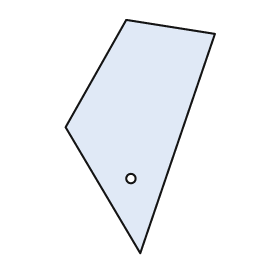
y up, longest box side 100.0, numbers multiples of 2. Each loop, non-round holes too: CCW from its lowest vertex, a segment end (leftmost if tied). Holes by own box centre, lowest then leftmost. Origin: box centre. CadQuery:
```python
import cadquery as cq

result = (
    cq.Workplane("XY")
    .moveTo(0.0, -50.0)
    .lineTo(32.0, 44.0)
    .lineTo(-6.0, 50.0)
    .lineTo(-32.0, 4.0)
    .close()
    .moveTo(-4.0, -18.0)
    .circle(2.0)
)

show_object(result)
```